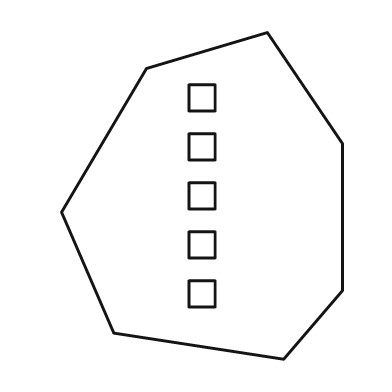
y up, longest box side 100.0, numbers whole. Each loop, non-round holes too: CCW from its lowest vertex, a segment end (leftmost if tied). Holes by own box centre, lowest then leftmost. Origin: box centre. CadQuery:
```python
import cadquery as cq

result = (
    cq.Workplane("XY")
    .moveTo(25.0, -50.0)
    .lineTo(43.0, -29.0)
    .lineTo(43.0, 16.0)
    .lineTo(20.0, 50.0)
    .lineTo(-17.0, 39.0)
    .lineTo(-43.0, -5.0)
    .lineTo(-27.0, -42.0)
    .close()
    .moveTo(-4.0, -34.0)
    .lineTo(4.0, -34.0)
    .lineTo(4.0, -26.0)
    .lineTo(-4.0, -26.0)
    .close()
    .moveTo(-4.0, -19.0)
    .lineTo(4.0, -19.0)
    .lineTo(4.0, -11.0)
    .lineTo(-4.0, -11.0)
    .close()
    .moveTo(-4.0, -4.0)
    .lineTo(4.0, -4.0)
    .lineTo(4.0, 4.0)
    .lineTo(-4.0, 4.0)
    .close()
    .moveTo(-4.0, 11.0)
    .lineTo(4.0, 11.0)
    .lineTo(4.0, 19.0)
    .lineTo(-4.0, 19.0)
    .close()
    .moveTo(-4.0, 26.0)
    .lineTo(4.0, 26.0)
    .lineTo(4.0, 34.0)
    .lineTo(-4.0, 34.0)
    .close()
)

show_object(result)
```